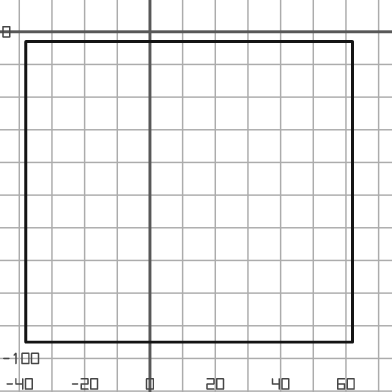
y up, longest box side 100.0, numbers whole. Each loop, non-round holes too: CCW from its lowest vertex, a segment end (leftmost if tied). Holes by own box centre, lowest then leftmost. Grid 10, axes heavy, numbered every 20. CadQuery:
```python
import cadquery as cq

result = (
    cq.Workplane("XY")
    .moveTo(-38.0, -95.0)
    .lineTo(62.0, -95.0)
    .lineTo(62.0, -3.0)
    .lineTo(-38.0, -3.0)
    .close()
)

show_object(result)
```